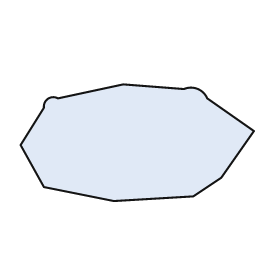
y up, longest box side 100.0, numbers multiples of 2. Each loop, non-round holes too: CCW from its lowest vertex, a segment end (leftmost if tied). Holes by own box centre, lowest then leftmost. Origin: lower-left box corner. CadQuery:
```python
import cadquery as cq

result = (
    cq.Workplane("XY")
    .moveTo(40.0, 0.0)
    .lineTo(74.0, 2.0)
    .lineTo(86.0, 10.0)
    .lineTo(100.0, 30.0)
    .lineTo(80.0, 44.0)
    .threePointArc((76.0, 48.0), (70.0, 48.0))
    .lineTo(44.0, 50.0)
    .lineTo(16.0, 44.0)
    .threePointArc((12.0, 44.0), (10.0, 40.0))
    .lineTo(0.0, 24.0)
    .lineTo(10.0, 6.0)
    .close()
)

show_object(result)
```